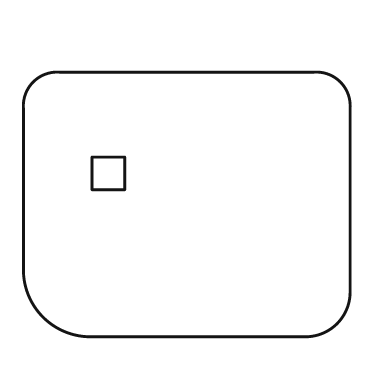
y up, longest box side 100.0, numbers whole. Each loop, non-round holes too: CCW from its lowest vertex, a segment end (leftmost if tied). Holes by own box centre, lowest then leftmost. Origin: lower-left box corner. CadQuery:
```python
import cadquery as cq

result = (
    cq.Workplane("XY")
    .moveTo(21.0, 0.0)
    .lineTo(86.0, 0.0)
    .threePointArc((96.0, 4.0), (100.0, 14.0))
    .lineTo(100.0, 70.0)
    .threePointArc((97.0, 78.0), (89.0, 81.0))
    .lineTo(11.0, 81.0)
    .threePointArc((3.0, 78.0), (0.0, 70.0))
    .lineTo(0.0, 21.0)
    .threePointArc((6.0, 6.0), (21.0, 0.0))
    .close()
    .moveTo(21.0, 45.0)
    .lineTo(31.0, 45.0)
    .lineTo(31.0, 55.0)
    .lineTo(21.0, 55.0)
    .close()
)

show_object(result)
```